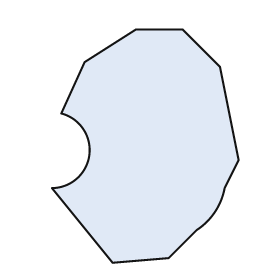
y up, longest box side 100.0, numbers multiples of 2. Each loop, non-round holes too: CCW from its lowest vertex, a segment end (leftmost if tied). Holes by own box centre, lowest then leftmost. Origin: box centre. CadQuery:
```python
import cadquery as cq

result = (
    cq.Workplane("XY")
    .moveTo(-14.0, -50.0)
    .lineTo(10.0, -48.0)
    .lineTo(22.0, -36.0)
    .threePointArc((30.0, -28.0), (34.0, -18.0))
    .lineTo(40.0, -6.0)
    .lineTo(32.0, 34.0)
    .lineTo(16.0, 50.0)
    .lineTo(-4.0, 50.0)
    .lineTo(-26.0, 36.0)
    .lineTo(-36.0, 14.0)
    .threePointArc((-24.0, -4.0), (-40.0, -18.0))
    .close()
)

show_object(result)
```